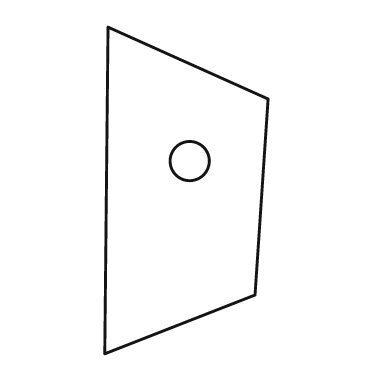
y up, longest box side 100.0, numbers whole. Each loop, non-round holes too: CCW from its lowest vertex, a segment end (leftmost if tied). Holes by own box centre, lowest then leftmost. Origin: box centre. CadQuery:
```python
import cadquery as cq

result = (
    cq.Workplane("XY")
    .moveTo(-25.0, -50.0)
    .lineTo(21.0, -32.0)
    .lineTo(25.0, 28.0)
    .lineTo(-24.0, 50.0)
    .close()
    .moveTo(1.0, 9.0)
    .circle(6.0)
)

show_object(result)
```